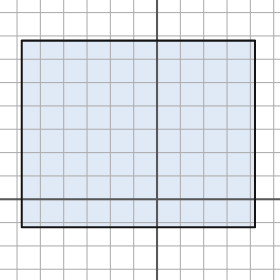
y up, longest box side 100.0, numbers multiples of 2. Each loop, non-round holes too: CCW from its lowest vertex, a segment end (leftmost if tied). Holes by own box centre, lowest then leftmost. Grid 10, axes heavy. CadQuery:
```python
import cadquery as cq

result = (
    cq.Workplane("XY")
    .moveTo(-58.0, -12.0)
    .lineTo(42.0, -12.0)
    .lineTo(42.0, 68.0)
    .lineTo(-58.0, 68.0)
    .close()
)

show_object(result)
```